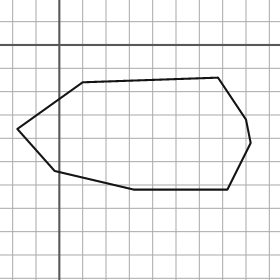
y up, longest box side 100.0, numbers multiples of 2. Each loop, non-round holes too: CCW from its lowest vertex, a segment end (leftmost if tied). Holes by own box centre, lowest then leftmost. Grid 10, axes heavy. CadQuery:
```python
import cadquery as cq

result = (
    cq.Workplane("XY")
    .moveTo(32.0, -62.0)
    .lineTo(72.0, -62.0)
    .lineTo(82.0, -42.0)
    .lineTo(80.0, -32.0)
    .lineTo(68.0, -14.0)
    .lineTo(10.0, -16.0)
    .lineTo(-18.0, -36.0)
    .lineTo(-2.0, -54.0)
    .close()
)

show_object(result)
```